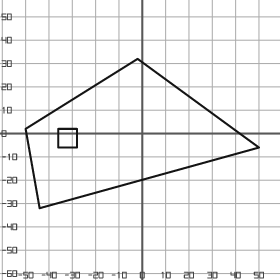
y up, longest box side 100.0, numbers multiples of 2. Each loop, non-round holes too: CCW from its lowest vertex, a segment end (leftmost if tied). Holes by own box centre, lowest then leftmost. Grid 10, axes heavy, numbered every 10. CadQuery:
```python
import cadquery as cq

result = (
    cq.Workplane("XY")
    .moveTo(-44.0, -32.0)
    .lineTo(50.0, -6.0)
    .lineTo(-2.0, 32.0)
    .lineTo(-50.0, 2.0)
    .close()
    .moveTo(-36.0, -6.0)
    .lineTo(-28.0, -6.0)
    .lineTo(-28.0, 2.0)
    .lineTo(-36.0, 2.0)
    .close()
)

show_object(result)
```